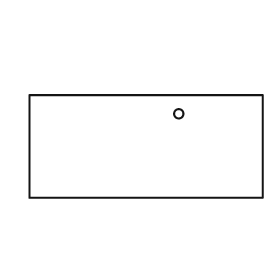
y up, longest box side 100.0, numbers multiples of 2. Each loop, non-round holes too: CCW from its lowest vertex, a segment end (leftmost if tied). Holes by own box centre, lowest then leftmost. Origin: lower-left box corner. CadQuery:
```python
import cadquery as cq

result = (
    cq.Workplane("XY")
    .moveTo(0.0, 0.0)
    .lineTo(100.0, 0.0)
    .lineTo(100.0, 44.0)
    .lineTo(0.0, 44.0)
    .close()
    .moveTo(64.0, 36.0)
    .circle(2.0)
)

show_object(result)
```